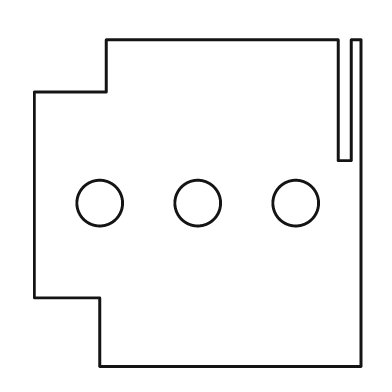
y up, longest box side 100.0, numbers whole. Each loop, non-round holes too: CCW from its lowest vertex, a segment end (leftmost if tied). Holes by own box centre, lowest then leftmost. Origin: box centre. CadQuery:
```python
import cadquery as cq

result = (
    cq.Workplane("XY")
    .moveTo(-30.0, -50.0)
    .lineTo(50.0, -50.0)
    .lineTo(50.0, 50.0)
    .lineTo(47.0, 50.0)
    .lineTo(47.0, 13.0)
    .lineTo(43.0, 13.0)
    .lineTo(43.0, 50.0)
    .lineTo(-28.0, 50.0)
    .lineTo(-28.0, 34.0)
    .lineTo(-50.0, 34.0)
    .lineTo(-50.0, -29.0)
    .lineTo(-30.0, -29.0)
    .close()
    .moveTo(-30.0, 0.0)
    .circle(7.0)
    .moveTo(0.0, 0.0)
    .circle(7.0)
    .moveTo(30.0, 0.0)
    .circle(7.0)
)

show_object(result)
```